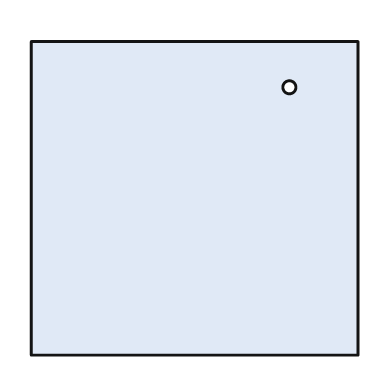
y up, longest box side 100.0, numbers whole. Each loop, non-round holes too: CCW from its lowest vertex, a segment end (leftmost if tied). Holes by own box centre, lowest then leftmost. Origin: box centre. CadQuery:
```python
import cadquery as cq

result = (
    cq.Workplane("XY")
    .moveTo(-50.0, -48.0)
    .lineTo(50.0, -48.0)
    .lineTo(50.0, 48.0)
    .lineTo(-50.0, 48.0)
    .close()
    .moveTo(29.0, 34.0)
    .circle(2.0)
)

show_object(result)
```